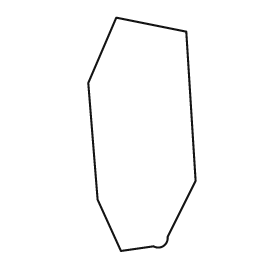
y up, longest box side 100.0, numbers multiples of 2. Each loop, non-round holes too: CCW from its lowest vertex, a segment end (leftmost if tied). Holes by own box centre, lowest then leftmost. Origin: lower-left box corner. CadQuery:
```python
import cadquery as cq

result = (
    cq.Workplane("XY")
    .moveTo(14.0, 0.0)
    .lineTo(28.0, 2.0)
    .threePointArc((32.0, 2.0), (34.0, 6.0))
    .lineTo(46.0, 30.0)
    .lineTo(42.0, 94.0)
    .lineTo(12.0, 100.0)
    .lineTo(0.0, 72.0)
    .lineTo(4.0, 22.0)
    .close()
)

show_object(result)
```